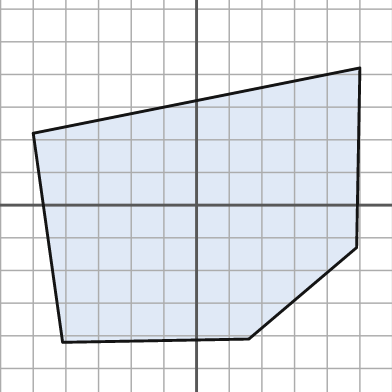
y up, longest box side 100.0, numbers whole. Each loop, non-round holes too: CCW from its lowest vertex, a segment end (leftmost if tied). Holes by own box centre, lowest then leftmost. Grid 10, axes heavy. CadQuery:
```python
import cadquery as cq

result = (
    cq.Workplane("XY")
    .moveTo(-41.0, -42.0)
    .lineTo(16.0, -41.0)
    .lineTo(49.0, -13.0)
    .lineTo(50.0, 42.0)
    .lineTo(-50.0, 22.0)
    .close()
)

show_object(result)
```